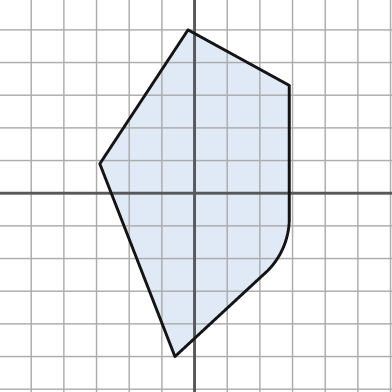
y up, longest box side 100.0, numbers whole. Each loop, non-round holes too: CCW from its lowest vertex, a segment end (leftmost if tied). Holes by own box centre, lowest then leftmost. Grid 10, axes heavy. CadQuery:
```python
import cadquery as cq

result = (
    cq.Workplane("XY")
    .moveTo(-6.0, -50.0)
    .lineTo(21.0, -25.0)
    .threePointArc((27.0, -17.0), (29.0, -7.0))
    .lineTo(29.0, 33.0)
    .lineTo(-2.0, 50.0)
    .lineTo(-29.0, 9.0)
    .close()
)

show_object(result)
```